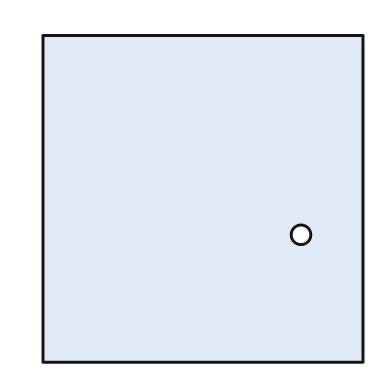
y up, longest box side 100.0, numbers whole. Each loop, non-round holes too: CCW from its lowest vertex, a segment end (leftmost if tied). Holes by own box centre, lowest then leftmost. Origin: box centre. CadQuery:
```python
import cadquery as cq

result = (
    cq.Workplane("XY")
    .moveTo(-49.0, -50.0)
    .lineTo(49.0, -50.0)
    .lineTo(49.0, 50.0)
    .lineTo(-49.0, 50.0)
    .close()
    .moveTo(30.0, -11.0)
    .circle(3.0)
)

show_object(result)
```